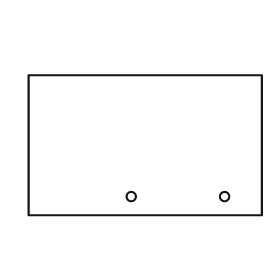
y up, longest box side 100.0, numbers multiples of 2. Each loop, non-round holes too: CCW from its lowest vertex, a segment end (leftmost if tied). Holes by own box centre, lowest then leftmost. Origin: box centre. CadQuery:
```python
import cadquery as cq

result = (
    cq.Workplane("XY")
    .moveTo(-50.0, -30.0)
    .lineTo(50.0, -30.0)
    .lineTo(50.0, 30.0)
    .lineTo(-50.0, 30.0)
    .close()
    .moveTo(-6.0, -22.0)
    .circle(2.0)
    .moveTo(34.0, -22.0)
    .circle(2.0)
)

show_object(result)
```